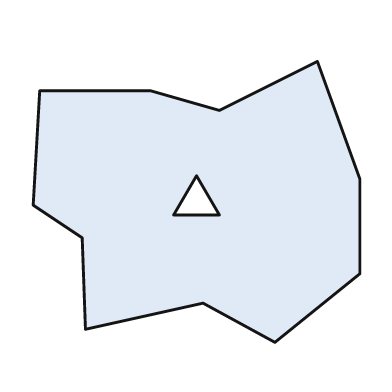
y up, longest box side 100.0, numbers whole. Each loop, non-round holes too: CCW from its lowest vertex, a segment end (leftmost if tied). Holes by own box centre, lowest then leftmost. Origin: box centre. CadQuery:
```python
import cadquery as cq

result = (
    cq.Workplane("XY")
    .moveTo(24.0, -43.0)
    .lineTo(50.0, -22.0)
    .lineTo(50.0, 7.0)
    .lineTo(37.0, 43.0)
    .lineTo(7.0, 28.0)
    .lineTo(-14.0, 34.0)
    .lineTo(-48.0, 34.0)
    .lineTo(-50.0, -1.0)
    .lineTo(-35.0, -11.0)
    .lineTo(-34.0, -39.0)
    .lineTo(2.0, -31.0)
    .close()
    .moveTo(-7.0, -4.0)
    .lineTo(7.0, -4.0)
    .lineTo(0.0, 8.0)
    .close()
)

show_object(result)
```